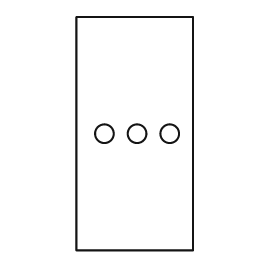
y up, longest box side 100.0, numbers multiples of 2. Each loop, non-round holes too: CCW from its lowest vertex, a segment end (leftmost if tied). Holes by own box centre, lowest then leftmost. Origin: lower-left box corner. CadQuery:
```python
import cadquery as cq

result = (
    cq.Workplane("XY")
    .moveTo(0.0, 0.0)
    .lineTo(50.0, 0.0)
    .lineTo(50.0, 100.0)
    .lineTo(0.0, 100.0)
    .close()
    .moveTo(12.0, 50.0)
    .circle(4.0)
    .moveTo(26.0, 50.0)
    .circle(4.0)
    .moveTo(40.0, 50.0)
    .circle(4.0)
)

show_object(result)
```